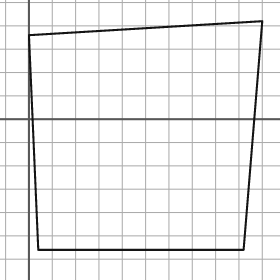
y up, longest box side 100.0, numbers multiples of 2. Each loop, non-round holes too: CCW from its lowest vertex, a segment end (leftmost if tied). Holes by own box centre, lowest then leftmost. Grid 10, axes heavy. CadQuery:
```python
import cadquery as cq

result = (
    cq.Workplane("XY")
    .moveTo(4.0, -56.0)
    .lineTo(92.0, -56.0)
    .lineTo(100.0, 42.0)
    .lineTo(0.0, 36.0)
    .close()
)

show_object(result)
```